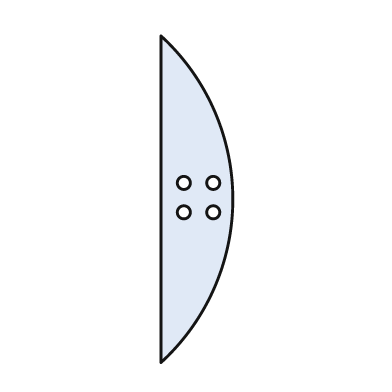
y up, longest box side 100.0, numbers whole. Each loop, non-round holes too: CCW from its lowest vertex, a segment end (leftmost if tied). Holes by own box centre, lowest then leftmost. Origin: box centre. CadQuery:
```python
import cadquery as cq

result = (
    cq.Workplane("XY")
    .moveTo(-11.0, -50.0)
    .threePointArc((11.0, 0.0), (-11.0, 50.0))
    .close()
    .moveTo(-4.0, -4.0)
    .circle(2.0)
    .moveTo(5.0, -4.0)
    .circle(2.0)
    .moveTo(-4.0, 5.0)
    .circle(2.0)
    .moveTo(5.0, 5.0)
    .circle(2.0)
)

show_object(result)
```